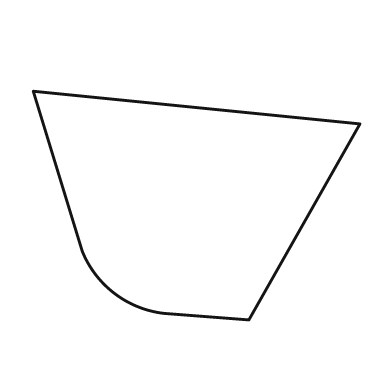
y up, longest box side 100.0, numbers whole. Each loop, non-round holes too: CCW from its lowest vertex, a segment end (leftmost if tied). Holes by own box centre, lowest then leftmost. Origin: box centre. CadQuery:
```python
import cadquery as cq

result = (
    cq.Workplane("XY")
    .moveTo(16.0, -35.0)
    .lineTo(50.0, 25.0)
    .lineTo(-50.0, 35.0)
    .lineTo(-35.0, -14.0)
    .threePointArc((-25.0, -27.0), (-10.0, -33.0))
    .close()
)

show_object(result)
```